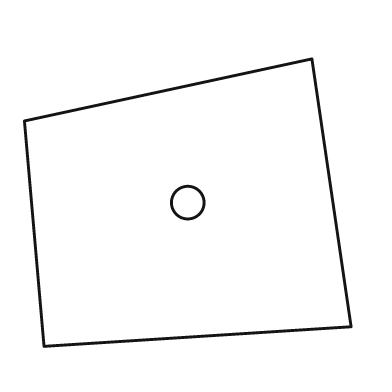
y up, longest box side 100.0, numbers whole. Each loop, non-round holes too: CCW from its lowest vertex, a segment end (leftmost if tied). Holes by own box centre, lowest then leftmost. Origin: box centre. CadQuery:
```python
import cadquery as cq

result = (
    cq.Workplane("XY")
    .moveTo(-44.0, -44.0)
    .lineTo(50.0, -38.0)
    .lineTo(38.0, 44.0)
    .lineTo(-50.0, 25.0)
    .close()
    .moveTo(0.0, 0.0)
    .circle(5.0)
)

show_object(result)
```